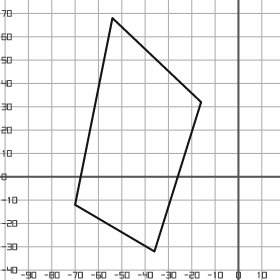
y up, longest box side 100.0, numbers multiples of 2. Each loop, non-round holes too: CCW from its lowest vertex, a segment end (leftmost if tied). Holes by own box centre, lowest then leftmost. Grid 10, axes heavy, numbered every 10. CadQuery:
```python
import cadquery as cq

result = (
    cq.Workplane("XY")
    .moveTo(-36.0, -32.0)
    .lineTo(-16.0, 32.0)
    .lineTo(-54.0, 68.0)
    .lineTo(-70.0, -12.0)
    .close()
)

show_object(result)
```